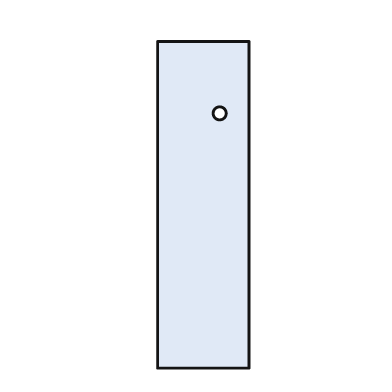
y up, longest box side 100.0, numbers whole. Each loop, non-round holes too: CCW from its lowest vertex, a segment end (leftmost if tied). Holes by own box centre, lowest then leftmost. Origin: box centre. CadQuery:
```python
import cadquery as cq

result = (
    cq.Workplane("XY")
    .moveTo(-14.0, -50.0)
    .lineTo(14.0, -50.0)
    .lineTo(14.0, 50.0)
    .lineTo(-14.0, 50.0)
    .close()
    .moveTo(5.0, 28.0)
    .circle(2.0)
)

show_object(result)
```